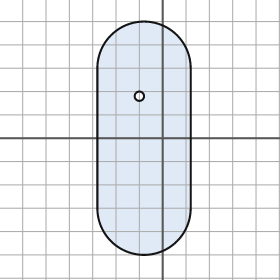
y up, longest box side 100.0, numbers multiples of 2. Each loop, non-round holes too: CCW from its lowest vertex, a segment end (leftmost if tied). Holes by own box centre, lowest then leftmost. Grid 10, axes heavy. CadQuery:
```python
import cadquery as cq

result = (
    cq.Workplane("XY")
    .moveTo(-28.0, -30.0)
    .threePointArc((-8.0, -50.0), (12.0, -30.0))
    .lineTo(12.0, 30.0)
    .threePointArc((-8.0, 50.0), (-28.0, 30.0))
    .close()
    .moveTo(-10.0, 18.0)
    .circle(2.0)
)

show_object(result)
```